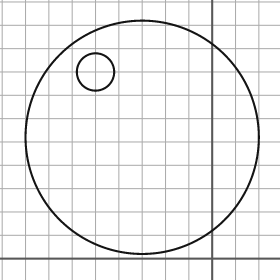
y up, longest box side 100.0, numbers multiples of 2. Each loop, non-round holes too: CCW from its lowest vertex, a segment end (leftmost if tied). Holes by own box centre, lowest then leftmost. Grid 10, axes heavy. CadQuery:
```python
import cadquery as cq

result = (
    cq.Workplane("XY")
    .moveTo(-30.0, 52.0)
    .circle(50.0)
    .moveTo(-50.0, 80.0)
    .circle(8.0)
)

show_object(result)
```